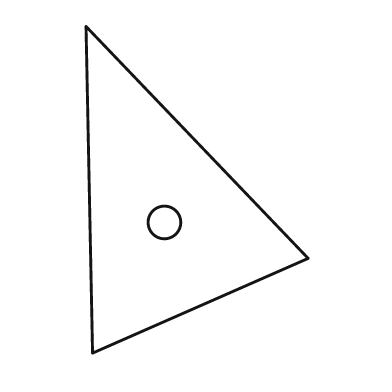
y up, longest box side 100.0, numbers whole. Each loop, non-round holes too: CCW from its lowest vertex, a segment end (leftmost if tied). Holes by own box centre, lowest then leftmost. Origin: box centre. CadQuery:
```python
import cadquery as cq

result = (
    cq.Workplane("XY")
    .moveTo(-32.0, -50.0)
    .lineTo(34.0, -21.0)
    .lineTo(-34.0, 50.0)
    .close()
    .moveTo(-10.0, -10.0)
    .circle(5.0)
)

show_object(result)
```